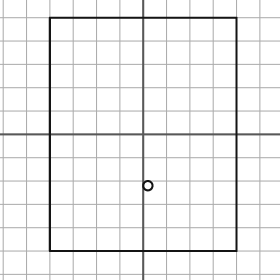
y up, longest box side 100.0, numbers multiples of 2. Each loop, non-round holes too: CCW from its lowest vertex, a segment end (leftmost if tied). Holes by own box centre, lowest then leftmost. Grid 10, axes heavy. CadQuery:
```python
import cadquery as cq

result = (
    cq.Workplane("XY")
    .moveTo(-40.0, -50.0)
    .lineTo(40.0, -50.0)
    .lineTo(40.0, 50.0)
    .lineTo(-40.0, 50.0)
    .close()
    .moveTo(2.0, -22.0)
    .circle(2.0)
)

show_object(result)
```